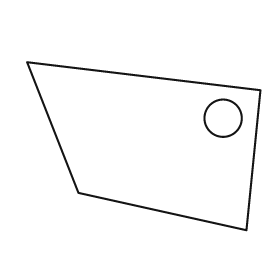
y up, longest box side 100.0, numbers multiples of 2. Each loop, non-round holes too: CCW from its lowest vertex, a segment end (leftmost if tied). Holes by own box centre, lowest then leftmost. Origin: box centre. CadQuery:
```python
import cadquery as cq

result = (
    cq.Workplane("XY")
    .moveTo(44.0, -36.0)
    .lineTo(50.0, 24.0)
    .lineTo(-50.0, 36.0)
    .lineTo(-28.0, -20.0)
    .close()
    .moveTo(34.0, 12.0)
    .circle(8.0)
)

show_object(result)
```